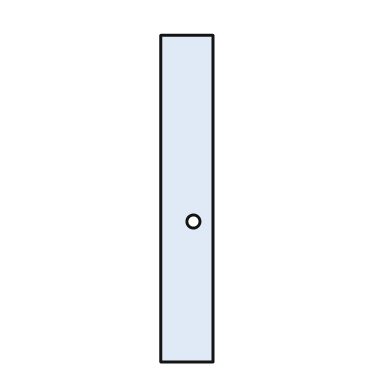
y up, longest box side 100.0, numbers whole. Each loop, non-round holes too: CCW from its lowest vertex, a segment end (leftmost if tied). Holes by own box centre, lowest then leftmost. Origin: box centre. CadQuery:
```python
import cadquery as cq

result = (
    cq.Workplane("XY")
    .moveTo(-8.0, -50.0)
    .lineTo(8.0, -50.0)
    .lineTo(8.0, 50.0)
    .lineTo(-8.0, 50.0)
    .close()
    .moveTo(2.0, -7.0)
    .circle(2.0)
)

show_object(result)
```